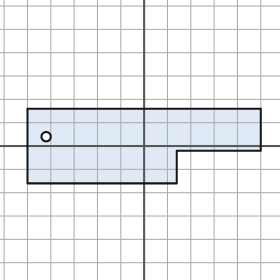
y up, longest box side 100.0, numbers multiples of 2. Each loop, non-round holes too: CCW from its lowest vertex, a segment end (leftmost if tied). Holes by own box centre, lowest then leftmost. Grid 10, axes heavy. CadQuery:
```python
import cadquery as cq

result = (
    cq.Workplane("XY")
    .moveTo(-50.0, -16.0)
    .lineTo(14.0, -16.0)
    .lineTo(14.0, -2.0)
    .lineTo(50.0, -2.0)
    .lineTo(50.0, 16.0)
    .lineTo(-50.0, 16.0)
    .close()
    .moveTo(-42.0, 4.0)
    .circle(2.0)
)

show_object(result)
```